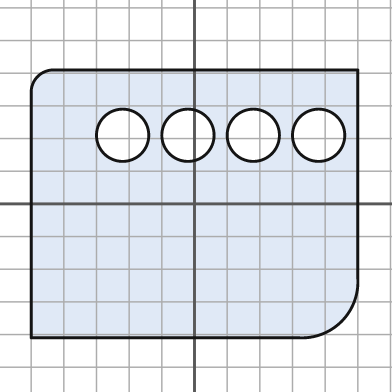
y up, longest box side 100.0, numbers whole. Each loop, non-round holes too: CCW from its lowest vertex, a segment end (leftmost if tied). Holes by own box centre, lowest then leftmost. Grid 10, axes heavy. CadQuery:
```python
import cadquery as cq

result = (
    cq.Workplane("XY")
    .moveTo(-50.0, -41.0)
    .lineTo(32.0, -41.0)
    .threePointArc((45.0, -36.0), (50.0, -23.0))
    .lineTo(50.0, 41.0)
    .lineTo(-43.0, 41.0)
    .threePointArc((-48.0, 39.0), (-50.0, 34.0))
    .close()
    .moveTo(-22.0, 21.0)
    .circle(8.0)
    .moveTo(-2.0, 21.0)
    .circle(8.0)
    .moveTo(18.0, 21.0)
    .circle(8.0)
    .moveTo(38.0, 21.0)
    .circle(8.0)
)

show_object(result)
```